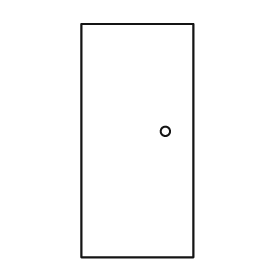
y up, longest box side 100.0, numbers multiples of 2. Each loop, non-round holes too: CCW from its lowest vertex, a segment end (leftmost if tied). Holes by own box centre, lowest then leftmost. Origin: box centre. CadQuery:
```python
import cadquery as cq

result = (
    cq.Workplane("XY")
    .moveTo(-24.0, -50.0)
    .lineTo(24.0, -50.0)
    .lineTo(24.0, 50.0)
    .lineTo(-24.0, 50.0)
    .close()
    .moveTo(12.0, 4.0)
    .circle(2.0)
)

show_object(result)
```